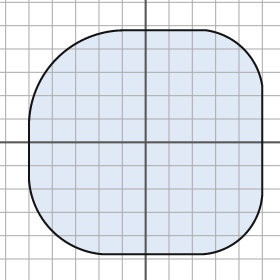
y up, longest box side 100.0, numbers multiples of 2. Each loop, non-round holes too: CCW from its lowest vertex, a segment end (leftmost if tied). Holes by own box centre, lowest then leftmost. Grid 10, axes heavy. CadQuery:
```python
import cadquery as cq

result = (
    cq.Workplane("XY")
    .moveTo(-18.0, -48.0)
    .lineTo(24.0, -48.0)
    .threePointArc((42.0, -40.0), (50.0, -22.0))
    .lineTo(50.0, 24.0)
    .threePointArc((42.0, 40.0), (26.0, 48.0))
    .lineTo(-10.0, 48.0)
    .threePointArc((-38.0, 36.0), (-50.0, 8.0))
    .lineTo(-50.0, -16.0)
    .threePointArc((-40.0, -38.0), (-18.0, -48.0))
    .close()
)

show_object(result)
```